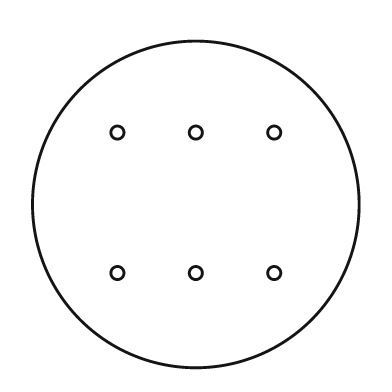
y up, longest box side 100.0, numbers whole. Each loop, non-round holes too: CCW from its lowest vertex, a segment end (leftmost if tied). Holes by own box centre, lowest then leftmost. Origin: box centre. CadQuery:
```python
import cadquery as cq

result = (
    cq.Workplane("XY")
    .moveTo(0.0, 0.0)
    .circle(50.0)
    .moveTo(-24.0, -21.0)
    .circle(2.0)
    .moveTo(0.0, -21.0)
    .circle(2.0)
    .moveTo(24.0, -21.0)
    .circle(2.0)
    .moveTo(-24.0, 22.0)
    .circle(2.0)
    .moveTo(0.0, 22.0)
    .circle(2.0)
    .moveTo(24.0, 22.0)
    .circle(2.0)
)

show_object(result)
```